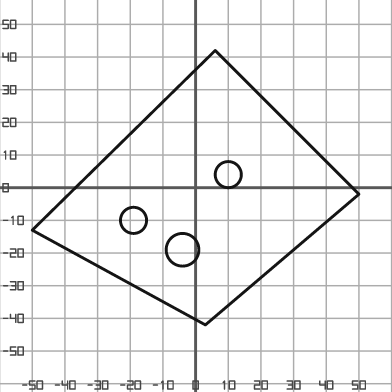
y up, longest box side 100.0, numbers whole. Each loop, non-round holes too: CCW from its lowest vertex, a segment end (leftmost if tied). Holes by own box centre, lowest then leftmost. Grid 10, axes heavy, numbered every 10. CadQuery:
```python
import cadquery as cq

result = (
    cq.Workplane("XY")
    .moveTo(3.0, -42.0)
    .lineTo(50.0, -2.0)
    .lineTo(6.0, 42.0)
    .lineTo(-50.0, -13.0)
    .close()
    .moveTo(-4.0, -19.0)
    .circle(5.0)
    .moveTo(-19.0, -10.0)
    .circle(4.0)
    .moveTo(10.0, 4.0)
    .circle(4.0)
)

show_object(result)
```